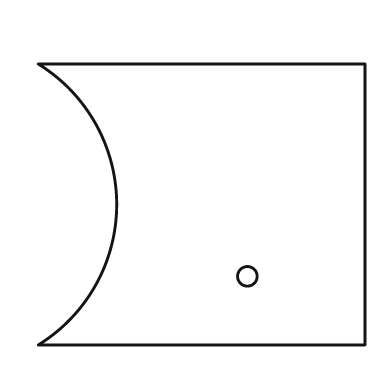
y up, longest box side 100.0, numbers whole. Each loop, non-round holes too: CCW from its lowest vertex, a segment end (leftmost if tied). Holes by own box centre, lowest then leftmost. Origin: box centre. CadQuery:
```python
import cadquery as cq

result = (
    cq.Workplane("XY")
    .moveTo(-50.0, -43.0)
    .lineTo(50.0, -43.0)
    .lineTo(50.0, 43.0)
    .lineTo(-50.0, 43.0)
    .threePointArc((-26.0, 0.0), (-50.0, -43.0))
    .close()
    .moveTo(14.0, -22.0)
    .circle(3.0)
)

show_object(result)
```